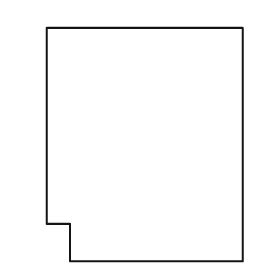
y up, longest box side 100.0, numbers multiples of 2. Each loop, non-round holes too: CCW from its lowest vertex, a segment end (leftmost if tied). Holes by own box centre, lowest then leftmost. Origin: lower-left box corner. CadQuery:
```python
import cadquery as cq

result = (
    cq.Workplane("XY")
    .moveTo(10.0, 0.0)
    .lineTo(84.0, 0.0)
    .lineTo(84.0, 100.0)
    .lineTo(0.0, 100.0)
    .lineTo(0.0, 16.0)
    .lineTo(10.0, 16.0)
    .close()
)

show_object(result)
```